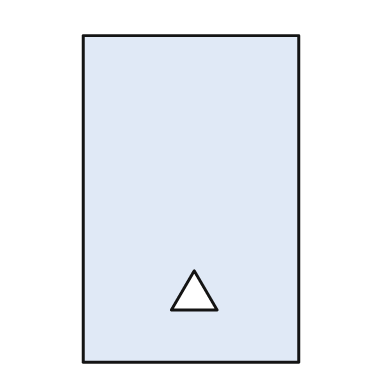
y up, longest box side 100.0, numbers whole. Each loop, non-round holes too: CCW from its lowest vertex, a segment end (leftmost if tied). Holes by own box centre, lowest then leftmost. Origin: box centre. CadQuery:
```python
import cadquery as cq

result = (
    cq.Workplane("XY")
    .moveTo(-33.0, -50.0)
    .lineTo(33.0, -50.0)
    .lineTo(33.0, 50.0)
    .lineTo(-33.0, 50.0)
    .close()
    .moveTo(-6.0, -34.0)
    .lineTo(8.0, -34.0)
    .lineTo(1.0, -22.0)
    .close()
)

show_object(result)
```